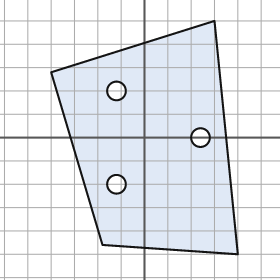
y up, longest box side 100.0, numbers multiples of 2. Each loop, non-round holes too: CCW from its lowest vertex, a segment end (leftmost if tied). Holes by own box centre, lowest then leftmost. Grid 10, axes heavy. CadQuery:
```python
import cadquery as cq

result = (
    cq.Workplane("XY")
    .moveTo(40.0, -50.0)
    .lineTo(30.0, 50.0)
    .lineTo(-40.0, 28.0)
    .lineTo(-18.0, -46.0)
    .close()
    .moveTo(-12.0, -20.0)
    .circle(4.0)
    .moveTo(24.0, 0.0)
    .circle(4.0)
    .moveTo(-12.0, 20.0)
    .circle(4.0)
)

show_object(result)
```